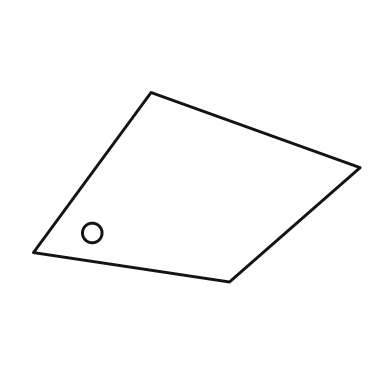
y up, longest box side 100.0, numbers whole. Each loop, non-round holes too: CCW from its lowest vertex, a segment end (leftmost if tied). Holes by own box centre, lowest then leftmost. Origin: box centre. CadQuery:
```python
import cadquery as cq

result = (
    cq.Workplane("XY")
    .moveTo(10.0, -29.0)
    .lineTo(50.0, 6.0)
    .lineTo(-14.0, 29.0)
    .lineTo(-50.0, -20.0)
    .close()
    .moveTo(-32.0, -14.0)
    .circle(3.0)
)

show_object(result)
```